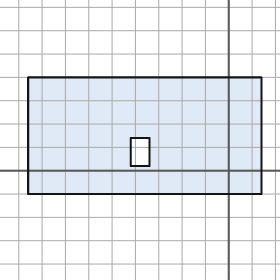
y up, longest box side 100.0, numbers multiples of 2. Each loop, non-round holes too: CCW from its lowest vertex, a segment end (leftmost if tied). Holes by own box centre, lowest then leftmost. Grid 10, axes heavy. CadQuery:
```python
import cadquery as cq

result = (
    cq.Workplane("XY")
    .moveTo(-86.0, -10.0)
    .lineTo(14.0, -10.0)
    .lineTo(14.0, 40.0)
    .lineTo(-86.0, 40.0)
    .close()
    .moveTo(-42.0, 2.0)
    .lineTo(-34.0, 2.0)
    .lineTo(-34.0, 14.0)
    .lineTo(-42.0, 14.0)
    .close()
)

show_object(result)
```